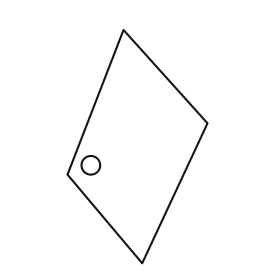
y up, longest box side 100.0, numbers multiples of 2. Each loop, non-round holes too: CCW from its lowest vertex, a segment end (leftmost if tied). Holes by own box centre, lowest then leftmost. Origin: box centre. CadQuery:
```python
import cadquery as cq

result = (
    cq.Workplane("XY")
    .moveTo(2.0, -50.0)
    .lineTo(30.0, 10.0)
    .lineTo(-6.0, 50.0)
    .lineTo(-30.0, -12.0)
    .close()
    .moveTo(-20.0, -8.0)
    .circle(4.0)
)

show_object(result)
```